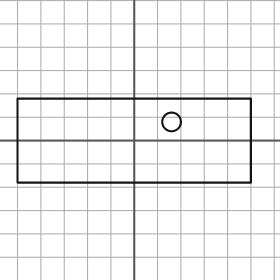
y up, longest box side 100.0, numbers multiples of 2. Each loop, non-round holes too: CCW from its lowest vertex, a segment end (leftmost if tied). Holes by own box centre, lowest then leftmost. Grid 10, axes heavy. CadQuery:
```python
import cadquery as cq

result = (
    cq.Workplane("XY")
    .moveTo(-50.0, -18.0)
    .lineTo(50.0, -18.0)
    .lineTo(50.0, 18.0)
    .lineTo(-50.0, 18.0)
    .close()
    .moveTo(16.0, 8.0)
    .circle(4.0)
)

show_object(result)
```